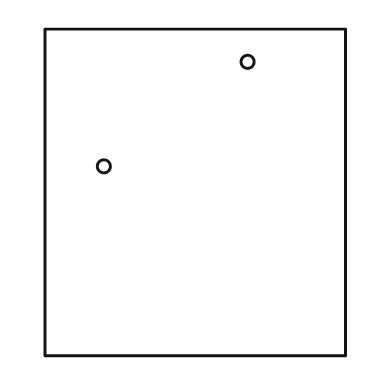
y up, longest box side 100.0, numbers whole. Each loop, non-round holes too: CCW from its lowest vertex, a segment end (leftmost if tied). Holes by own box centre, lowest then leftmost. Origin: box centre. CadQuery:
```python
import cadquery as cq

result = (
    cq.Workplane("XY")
    .moveTo(-46.0, -50.0)
    .lineTo(46.0, -50.0)
    .lineTo(46.0, 50.0)
    .lineTo(-46.0, 50.0)
    .close()
    .moveTo(-28.0, 8.0)
    .circle(2.0)
    .moveTo(16.0, 40.0)
    .circle(2.0)
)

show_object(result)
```